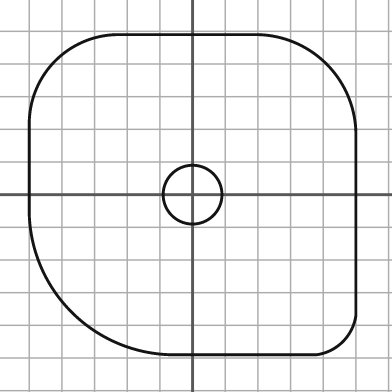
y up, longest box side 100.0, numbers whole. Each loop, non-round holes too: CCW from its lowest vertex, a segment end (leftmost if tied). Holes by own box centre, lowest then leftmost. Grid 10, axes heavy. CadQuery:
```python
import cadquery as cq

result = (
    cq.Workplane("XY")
    .moveTo(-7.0, -49.0)
    .lineTo(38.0, -49.0)
    .threePointArc((46.0, -45.0), (50.0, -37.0))
    .lineTo(50.0, 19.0)
    .threePointArc((41.0, 40.0), (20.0, 49.0))
    .lineTo(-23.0, 49.0)
    .threePointArc((-42.0, 41.0), (-50.0, 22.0))
    .lineTo(-50.0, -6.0)
    .threePointArc((-37.0, -36.0), (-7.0, -49.0))
    .close()
    .moveTo(0.0, 0.0)
    .circle(9.0)
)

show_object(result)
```